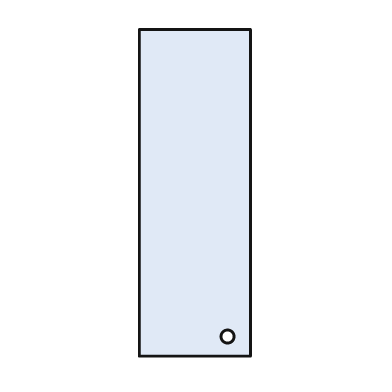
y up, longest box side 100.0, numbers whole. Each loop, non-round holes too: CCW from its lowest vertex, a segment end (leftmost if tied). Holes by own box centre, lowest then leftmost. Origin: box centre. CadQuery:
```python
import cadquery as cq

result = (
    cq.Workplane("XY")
    .moveTo(-17.0, -50.0)
    .lineTo(17.0, -50.0)
    .lineTo(17.0, 50.0)
    .lineTo(-17.0, 50.0)
    .close()
    .moveTo(10.0, -44.0)
    .circle(2.0)
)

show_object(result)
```